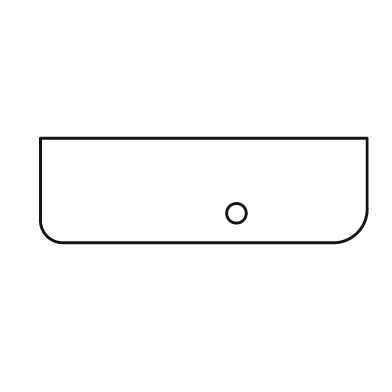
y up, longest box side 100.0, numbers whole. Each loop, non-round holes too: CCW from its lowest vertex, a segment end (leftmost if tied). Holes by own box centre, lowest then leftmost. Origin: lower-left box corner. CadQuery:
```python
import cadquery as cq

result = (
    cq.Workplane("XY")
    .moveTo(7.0, 0.0)
    .lineTo(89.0, 0.0)
    .threePointArc((97.0, 3.0), (100.0, 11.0))
    .lineTo(100.0, 32.0)
    .lineTo(0.0, 32.0)
    .lineTo(0.0, 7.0)
    .threePointArc((2.0, 2.0), (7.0, 0.0))
    .close()
    .moveTo(60.0, 9.0)
    .circle(3.0)
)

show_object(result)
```